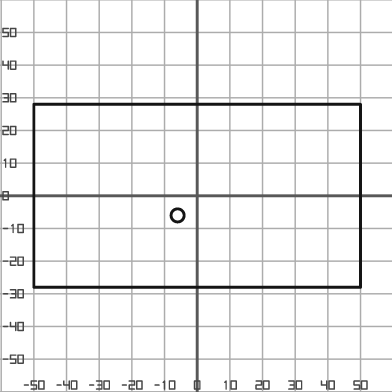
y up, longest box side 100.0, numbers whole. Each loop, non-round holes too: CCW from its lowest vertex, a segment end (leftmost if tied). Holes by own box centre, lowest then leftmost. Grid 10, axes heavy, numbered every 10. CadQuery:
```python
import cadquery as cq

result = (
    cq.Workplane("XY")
    .moveTo(-50.0, -28.0)
    .lineTo(50.0, -28.0)
    .lineTo(50.0, 28.0)
    .lineTo(-50.0, 28.0)
    .close()
    .moveTo(-6.0, -6.0)
    .circle(2.0)
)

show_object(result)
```